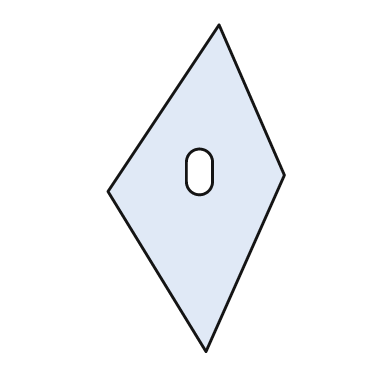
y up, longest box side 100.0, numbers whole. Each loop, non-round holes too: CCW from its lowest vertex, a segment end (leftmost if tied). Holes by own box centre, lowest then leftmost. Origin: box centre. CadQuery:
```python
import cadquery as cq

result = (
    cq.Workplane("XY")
    .moveTo(3.0, -50.0)
    .lineTo(27.0, 4.0)
    .lineTo(7.0, 50.0)
    .lineTo(-27.0, -1.0)
    .close()
    .moveTo(-3.0, 2.0)
    .threePointArc((1.0, -2.0), (5.0, 2.0))
    .lineTo(5.0, 8.0)
    .threePointArc((1.0, 12.0), (-3.0, 8.0))
    .close()
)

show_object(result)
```